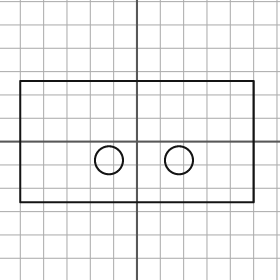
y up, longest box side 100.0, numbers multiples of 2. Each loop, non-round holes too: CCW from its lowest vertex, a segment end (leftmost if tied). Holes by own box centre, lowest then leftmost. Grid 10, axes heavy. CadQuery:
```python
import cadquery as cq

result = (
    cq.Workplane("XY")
    .moveTo(-50.0, -26.0)
    .lineTo(50.0, -26.0)
    .lineTo(50.0, 26.0)
    .lineTo(-50.0, 26.0)
    .close()
    .moveTo(-12.0, -8.0)
    .circle(6.0)
    .moveTo(18.0, -8.0)
    .circle(6.0)
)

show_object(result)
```